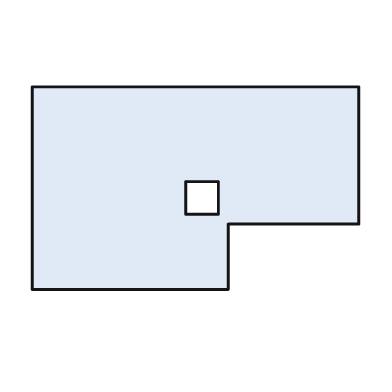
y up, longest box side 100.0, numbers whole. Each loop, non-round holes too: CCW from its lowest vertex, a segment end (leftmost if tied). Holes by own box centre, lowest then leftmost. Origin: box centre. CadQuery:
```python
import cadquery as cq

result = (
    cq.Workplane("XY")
    .moveTo(-50.0, -31.0)
    .lineTo(10.0, -31.0)
    .lineTo(10.0, -11.0)
    .lineTo(50.0, -11.0)
    .lineTo(50.0, 31.0)
    .lineTo(-50.0, 31.0)
    .close()
    .moveTo(-3.0, -8.0)
    .lineTo(7.0, -8.0)
    .lineTo(7.0, 2.0)
    .lineTo(-3.0, 2.0)
    .close()
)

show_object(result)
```